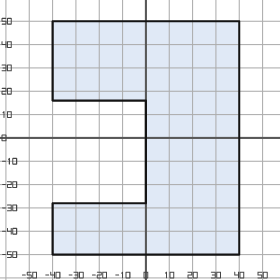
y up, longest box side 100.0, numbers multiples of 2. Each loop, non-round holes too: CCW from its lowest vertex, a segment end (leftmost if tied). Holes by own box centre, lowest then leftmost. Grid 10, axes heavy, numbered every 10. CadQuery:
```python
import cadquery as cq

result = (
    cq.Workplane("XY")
    .moveTo(-40.0, -50.0)
    .lineTo(40.0, -50.0)
    .lineTo(40.0, 50.0)
    .lineTo(-40.0, 50.0)
    .lineTo(-40.0, 16.0)
    .lineTo(0.0, 16.0)
    .lineTo(0.0, -28.0)
    .lineTo(-40.0, -28.0)
    .close()
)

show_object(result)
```